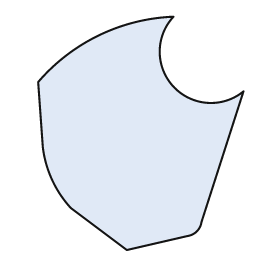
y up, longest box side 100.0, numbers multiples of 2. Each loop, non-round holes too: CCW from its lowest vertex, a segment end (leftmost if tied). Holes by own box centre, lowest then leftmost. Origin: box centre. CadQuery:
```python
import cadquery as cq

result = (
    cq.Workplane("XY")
    .moveTo(-6.0, -50.0)
    .lineTo(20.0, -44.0)
    .threePointArc((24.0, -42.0), (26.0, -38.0))
    .lineTo(44.0, 18.0)
    .threePointArc((14.0, 20.0), (14.0, 50.0))
    .threePointArc((-18.0, 42.0), (-44.0, 22.0))
    .lineTo(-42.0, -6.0)
    .threePointArc((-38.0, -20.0), (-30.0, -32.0))
    .close()
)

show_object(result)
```